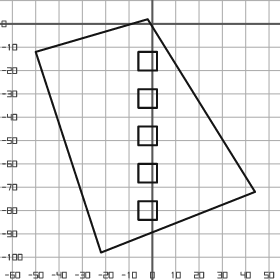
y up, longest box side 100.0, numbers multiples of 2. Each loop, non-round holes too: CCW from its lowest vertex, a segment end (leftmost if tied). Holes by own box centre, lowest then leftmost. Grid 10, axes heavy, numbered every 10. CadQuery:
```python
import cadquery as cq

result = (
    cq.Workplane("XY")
    .moveTo(-22.0, -98.0)
    .lineTo(44.0, -72.0)
    .lineTo(-2.0, 2.0)
    .lineTo(-50.0, -12.0)
    .close()
    .moveTo(-6.0, -84.0)
    .lineTo(2.0, -84.0)
    .lineTo(2.0, -76.0)
    .lineTo(-6.0, -76.0)
    .close()
    .moveTo(-6.0, -68.0)
    .lineTo(2.0, -68.0)
    .lineTo(2.0, -60.0)
    .lineTo(-6.0, -60.0)
    .close()
    .moveTo(-6.0, -52.0)
    .lineTo(2.0, -52.0)
    .lineTo(2.0, -44.0)
    .lineTo(-6.0, -44.0)
    .close()
    .moveTo(-6.0, -36.0)
    .lineTo(2.0, -36.0)
    .lineTo(2.0, -28.0)
    .lineTo(-6.0, -28.0)
    .close()
    .moveTo(-6.0, -20.0)
    .lineTo(2.0, -20.0)
    .lineTo(2.0, -12.0)
    .lineTo(-6.0, -12.0)
    .close()
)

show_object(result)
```